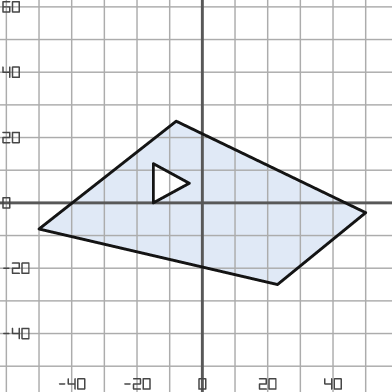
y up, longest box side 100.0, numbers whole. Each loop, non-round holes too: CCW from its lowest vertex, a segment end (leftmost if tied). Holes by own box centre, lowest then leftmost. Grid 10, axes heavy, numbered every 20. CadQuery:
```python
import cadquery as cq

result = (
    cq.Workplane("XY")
    .moveTo(23.0, -25.0)
    .lineTo(50.0, -3.0)
    .lineTo(-8.0, 25.0)
    .lineTo(-50.0, -8.0)
    .close()
    .moveTo(-15.0, 0.0)
    .lineTo(-4.0, 6.0)
    .lineTo(-15.0, 12.0)
    .close()
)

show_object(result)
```